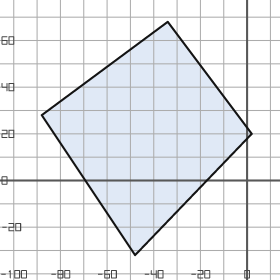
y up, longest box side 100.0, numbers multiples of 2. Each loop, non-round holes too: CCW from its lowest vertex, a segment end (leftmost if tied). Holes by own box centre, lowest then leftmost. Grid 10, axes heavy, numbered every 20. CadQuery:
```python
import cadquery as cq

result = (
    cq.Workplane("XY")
    .moveTo(-48.0, -32.0)
    .lineTo(2.0, 20.0)
    .lineTo(-34.0, 68.0)
    .lineTo(-88.0, 28.0)
    .close()
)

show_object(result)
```